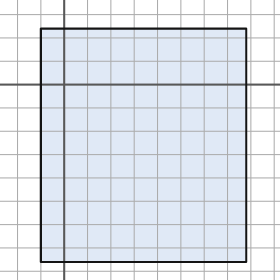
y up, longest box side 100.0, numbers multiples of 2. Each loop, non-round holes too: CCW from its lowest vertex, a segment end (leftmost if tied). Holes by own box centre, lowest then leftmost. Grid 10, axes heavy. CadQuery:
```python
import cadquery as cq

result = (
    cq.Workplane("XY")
    .moveTo(-10.0, -76.0)
    .lineTo(78.0, -76.0)
    .lineTo(78.0, 24.0)
    .lineTo(-10.0, 24.0)
    .close()
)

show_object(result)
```